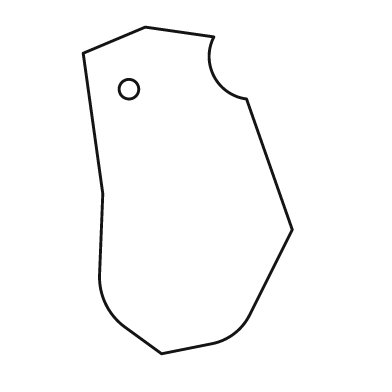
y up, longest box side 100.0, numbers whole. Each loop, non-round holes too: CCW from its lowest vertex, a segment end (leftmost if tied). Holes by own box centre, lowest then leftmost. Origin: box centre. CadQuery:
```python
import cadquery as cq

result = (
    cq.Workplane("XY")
    .moveTo(-8.0, -50.0)
    .lineTo(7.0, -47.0)
    .threePointArc((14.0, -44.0), (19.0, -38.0))
    .lineTo(32.0, -12.0)
    .lineTo(18.0, 28.0)
    .threePointArc((8.0, 35.0), (8.0, 47.0))
    .lineTo(-13.0, 50.0)
    .lineTo(-32.0, 42.0)
    .lineTo(-26.0, -1.0)
    .lineTo(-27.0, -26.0)
    .threePointArc((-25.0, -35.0), (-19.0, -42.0))
    .close()
    .moveTo(-18.0, 31.0)
    .circle(3.0)
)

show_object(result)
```